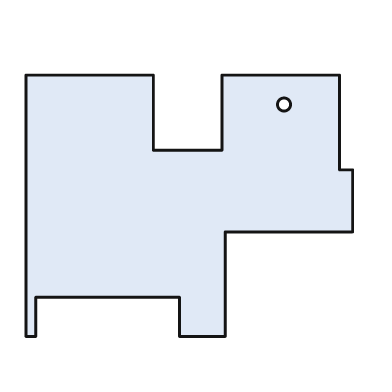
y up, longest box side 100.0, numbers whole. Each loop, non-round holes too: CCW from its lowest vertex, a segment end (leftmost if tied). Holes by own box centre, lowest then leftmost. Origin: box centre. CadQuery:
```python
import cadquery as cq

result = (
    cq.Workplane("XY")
    .moveTo(-50.0, -40.0)
    .lineTo(-47.0, -40.0)
    .lineTo(-47.0, -28.0)
    .lineTo(-3.0, -28.0)
    .lineTo(-3.0, -40.0)
    .lineTo(11.0, -40.0)
    .lineTo(11.0, -8.0)
    .lineTo(50.0, -8.0)
    .lineTo(50.0, 11.0)
    .lineTo(46.0, 11.0)
    .lineTo(46.0, 40.0)
    .lineTo(10.0, 40.0)
    .lineTo(10.0, 17.0)
    .lineTo(-11.0, 17.0)
    .lineTo(-11.0, 40.0)
    .lineTo(-50.0, 40.0)
    .close()
    .moveTo(29.0, 31.0)
    .circle(2.0)
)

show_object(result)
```